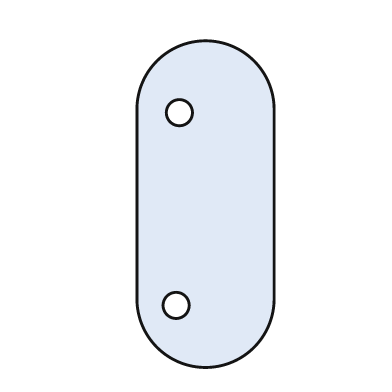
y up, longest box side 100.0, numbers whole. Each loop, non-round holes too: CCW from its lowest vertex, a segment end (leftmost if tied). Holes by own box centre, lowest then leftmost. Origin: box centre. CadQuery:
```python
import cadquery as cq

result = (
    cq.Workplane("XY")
    .moveTo(-21.0, -29.0)
    .threePointArc((0.0, -50.0), (21.0, -29.0))
    .lineTo(21.0, 29.0)
    .threePointArc((0.0, 50.0), (-21.0, 29.0))
    .close()
    .moveTo(-9.0, -31.0)
    .circle(4.0)
    .moveTo(-8.0, 28.0)
    .circle(4.0)
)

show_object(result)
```